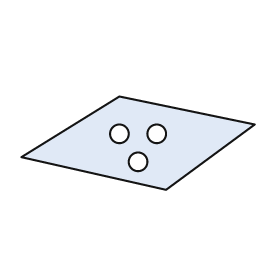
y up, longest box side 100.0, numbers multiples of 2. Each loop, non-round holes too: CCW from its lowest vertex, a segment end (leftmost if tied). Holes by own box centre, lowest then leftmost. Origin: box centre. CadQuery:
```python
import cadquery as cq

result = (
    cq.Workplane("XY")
    .moveTo(12.0, -20.0)
    .lineTo(50.0, 8.0)
    .lineTo(-8.0, 20.0)
    .lineTo(-50.0, -6.0)
    .close()
    .moveTo(0.0, -8.0)
    .circle(4.0)
    .moveTo(-8.0, 4.0)
    .circle(4.0)
    .moveTo(8.0, 4.0)
    .circle(4.0)
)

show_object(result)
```